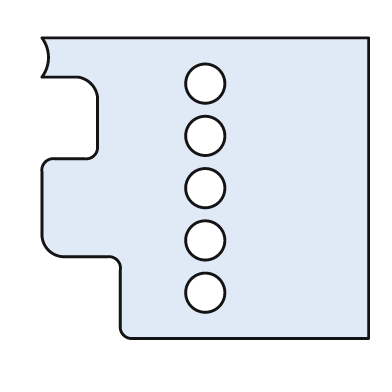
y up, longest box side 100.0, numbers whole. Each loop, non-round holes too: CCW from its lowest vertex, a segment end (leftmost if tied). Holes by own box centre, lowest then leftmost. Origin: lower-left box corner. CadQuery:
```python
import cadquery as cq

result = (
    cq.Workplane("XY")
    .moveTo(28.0, 0.0)
    .lineTo(100.0, 0.0)
    .lineTo(100.0, 92.0)
    .lineTo(0.0, 92.0)
    .threePointArc((2.0, 86.0), (0.0, 80.0))
    .lineTo(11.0, 80.0)
    .threePointArc((15.0, 78.0), (17.0, 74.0))
    .lineTo(17.0, 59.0)
    .threePointArc((16.0, 56.0), (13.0, 55.0))
    .lineTo(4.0, 55.0)
    .threePointArc((1.0, 54.0), (0.0, 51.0))
    .lineTo(0.0, 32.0)
    .threePointArc((2.0, 27.0), (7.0, 25.0))
    .lineTo(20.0, 25.0)
    .threePointArc((23.0, 24.0), (24.0, 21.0))
    .lineTo(24.0, 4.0)
    .threePointArc((25.0, 1.0), (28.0, 0.0))
    .close()
    .moveTo(50.0, 14.0)
    .circle(6.0)
    .moveTo(50.0, 30.0)
    .circle(6.0)
    .moveTo(50.0, 46.0)
    .circle(6.0)
    .moveTo(50.0, 62.0)
    .circle(6.0)
    .moveTo(50.0, 78.0)
    .circle(6.0)
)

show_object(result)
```